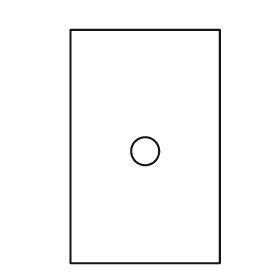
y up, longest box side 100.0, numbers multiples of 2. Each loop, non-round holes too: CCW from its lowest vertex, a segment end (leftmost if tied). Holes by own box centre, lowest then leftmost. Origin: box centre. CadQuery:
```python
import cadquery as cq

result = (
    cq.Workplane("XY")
    .moveTo(-32.0, -50.0)
    .lineTo(32.0, -50.0)
    .lineTo(32.0, 50.0)
    .lineTo(-32.0, 50.0)
    .close()
    .moveTo(0.0, -2.0)
    .circle(6.0)
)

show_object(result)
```